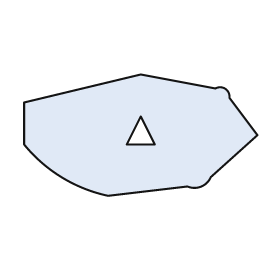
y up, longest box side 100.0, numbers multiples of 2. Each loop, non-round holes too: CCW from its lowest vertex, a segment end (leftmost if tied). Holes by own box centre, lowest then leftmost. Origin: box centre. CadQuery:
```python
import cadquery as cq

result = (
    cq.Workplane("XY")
    .moveTo(-14.0, -26.0)
    .lineTo(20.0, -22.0)
    .threePointArc((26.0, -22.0), (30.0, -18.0))
    .lineTo(50.0, 0.0)
    .lineTo(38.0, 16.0)
    .threePointArc((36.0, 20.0), (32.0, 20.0))
    .lineTo(0.0, 26.0)
    .lineTo(-50.0, 14.0)
    .lineTo(-50.0, -4.0)
    .threePointArc((-34.0, -18.0), (-14.0, -26.0))
    .close()
    .moveTo(-6.0, -4.0)
    .lineTo(6.0, -4.0)
    .lineTo(0.0, 8.0)
    .close()
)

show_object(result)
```